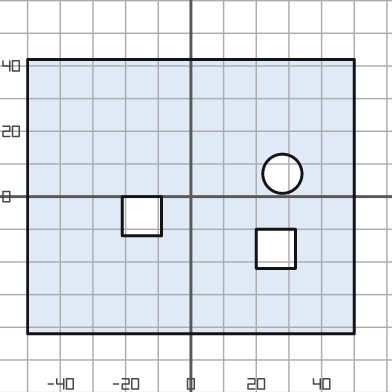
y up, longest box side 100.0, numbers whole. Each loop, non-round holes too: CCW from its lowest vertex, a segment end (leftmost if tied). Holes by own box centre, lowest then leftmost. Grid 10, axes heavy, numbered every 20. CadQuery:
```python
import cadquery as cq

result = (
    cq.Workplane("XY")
    .moveTo(-50.0, -42.0)
    .lineTo(50.0, -42.0)
    .lineTo(50.0, 42.0)
    .lineTo(-50.0, 42.0)
    .close()
    .moveTo(20.0, -22.0)
    .lineTo(32.0, -22.0)
    .lineTo(32.0, -10.0)
    .lineTo(20.0, -10.0)
    .close()
    .moveTo(-21.0, -12.0)
    .lineTo(-9.0, -12.0)
    .lineTo(-9.0, 0.0)
    .lineTo(-21.0, 0.0)
    .close()
    .moveTo(28.0, 7.0)
    .circle(6.0)
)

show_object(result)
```